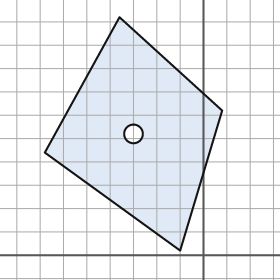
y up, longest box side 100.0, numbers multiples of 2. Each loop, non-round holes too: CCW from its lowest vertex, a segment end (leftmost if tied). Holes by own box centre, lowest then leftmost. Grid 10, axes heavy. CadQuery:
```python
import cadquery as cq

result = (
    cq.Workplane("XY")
    .moveTo(-10.0, 2.0)
    .lineTo(8.0, 62.0)
    .lineTo(-36.0, 102.0)
    .lineTo(-68.0, 44.0)
    .close()
    .moveTo(-30.0, 52.0)
    .circle(4.0)
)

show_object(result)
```